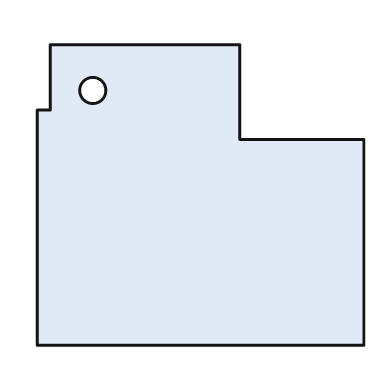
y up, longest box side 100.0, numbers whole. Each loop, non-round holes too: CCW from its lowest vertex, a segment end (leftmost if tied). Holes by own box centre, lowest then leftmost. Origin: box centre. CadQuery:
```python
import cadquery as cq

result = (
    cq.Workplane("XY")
    .moveTo(-50.0, -46.0)
    .lineTo(50.0, -46.0)
    .lineTo(50.0, 17.0)
    .lineTo(12.0, 17.0)
    .lineTo(12.0, 46.0)
    .lineTo(-46.0, 46.0)
    .lineTo(-46.0, 26.0)
    .lineTo(-50.0, 26.0)
    .close()
    .moveTo(-33.0, 32.0)
    .circle(4.0)
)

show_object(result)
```